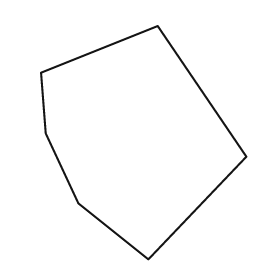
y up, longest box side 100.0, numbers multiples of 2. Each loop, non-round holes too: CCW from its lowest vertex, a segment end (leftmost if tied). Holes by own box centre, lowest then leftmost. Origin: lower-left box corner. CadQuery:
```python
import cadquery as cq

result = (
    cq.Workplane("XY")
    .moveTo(46.0, 0.0)
    .lineTo(88.0, 44.0)
    .lineTo(50.0, 100.0)
    .lineTo(0.0, 80.0)
    .lineTo(2.0, 54.0)
    .lineTo(16.0, 24.0)
    .close()
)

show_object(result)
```